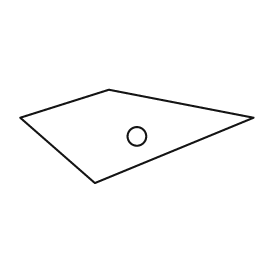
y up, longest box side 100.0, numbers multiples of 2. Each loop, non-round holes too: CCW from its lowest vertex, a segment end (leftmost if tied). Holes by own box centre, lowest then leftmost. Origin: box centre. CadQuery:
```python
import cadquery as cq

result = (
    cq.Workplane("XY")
    .moveTo(-18.0, -20.0)
    .lineTo(50.0, 8.0)
    .lineTo(-12.0, 20.0)
    .lineTo(-50.0, 8.0)
    .close()
    .moveTo(0.0, 0.0)
    .circle(4.0)
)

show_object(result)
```